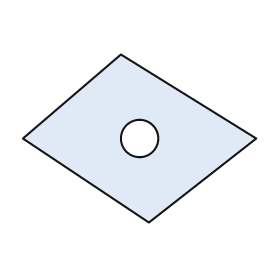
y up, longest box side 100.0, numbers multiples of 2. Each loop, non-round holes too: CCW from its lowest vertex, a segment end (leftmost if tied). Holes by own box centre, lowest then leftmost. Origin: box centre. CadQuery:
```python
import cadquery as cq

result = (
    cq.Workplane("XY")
    .moveTo(4.0, -36.0)
    .lineTo(50.0, 0.0)
    .lineTo(-8.0, 36.0)
    .lineTo(-50.0, 0.0)
    .close()
    .moveTo(0.0, 0.0)
    .circle(8.0)
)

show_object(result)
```